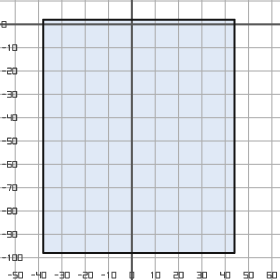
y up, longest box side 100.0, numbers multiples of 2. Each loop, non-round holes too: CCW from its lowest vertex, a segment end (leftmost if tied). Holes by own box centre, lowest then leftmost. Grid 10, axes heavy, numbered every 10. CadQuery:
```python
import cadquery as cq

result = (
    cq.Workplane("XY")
    .moveTo(-38.0, -98.0)
    .lineTo(44.0, -98.0)
    .lineTo(44.0, 2.0)
    .lineTo(-38.0, 2.0)
    .close()
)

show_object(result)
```